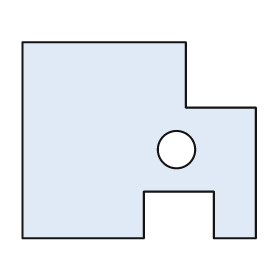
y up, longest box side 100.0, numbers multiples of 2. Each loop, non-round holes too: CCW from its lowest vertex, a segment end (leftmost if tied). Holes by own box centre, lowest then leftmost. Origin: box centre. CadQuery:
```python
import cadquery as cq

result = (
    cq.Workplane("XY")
    .moveTo(-50.0, -42.0)
    .lineTo(2.0, -42.0)
    .lineTo(2.0, -22.0)
    .lineTo(32.0, -22.0)
    .lineTo(32.0, -42.0)
    .lineTo(50.0, -42.0)
    .lineTo(50.0, 14.0)
    .lineTo(20.0, 14.0)
    .lineTo(20.0, 42.0)
    .lineTo(-50.0, 42.0)
    .close()
    .moveTo(16.0, -4.0)
    .circle(8.0)
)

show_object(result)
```